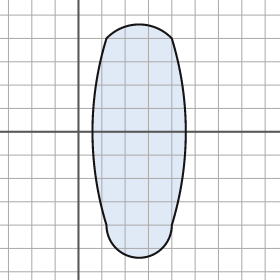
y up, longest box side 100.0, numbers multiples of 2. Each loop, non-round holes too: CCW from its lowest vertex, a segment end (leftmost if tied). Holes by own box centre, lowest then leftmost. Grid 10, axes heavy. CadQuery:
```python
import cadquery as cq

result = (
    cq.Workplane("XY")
    .moveTo(12.0, -40.0)
    .threePointArc((26.0, -54.0), (40.0, -40.0))
    .threePointArc((46.0, 0.0), (40.0, 40.0))
    .threePointArc((26.0, 46.0), (12.0, 40.0))
    .threePointArc((6.0, 0.0), (12.0, -40.0))
    .close()
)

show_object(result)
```